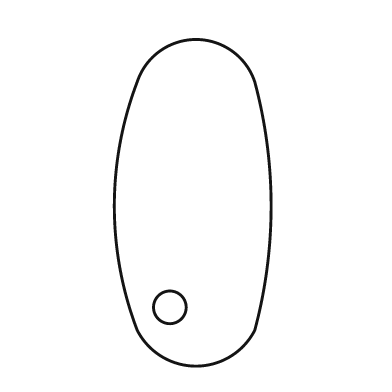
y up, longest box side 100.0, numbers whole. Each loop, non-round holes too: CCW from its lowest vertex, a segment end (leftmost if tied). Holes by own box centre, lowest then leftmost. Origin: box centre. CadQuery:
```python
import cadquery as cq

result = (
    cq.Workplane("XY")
    .moveTo(-17.0, -39.0)
    .threePointArc((1.0, -50.0), (19.0, -39.0))
    .threePointArc((24.0, -1.0), (19.0, 37.0))
    .threePointArc((1.0, 50.0), (-17.0, 37.0))
    .threePointArc((-24.0, -1.0), (-17.0, -39.0))
    .close()
    .moveTo(-7.0, -32.0)
    .circle(5.0)
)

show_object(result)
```